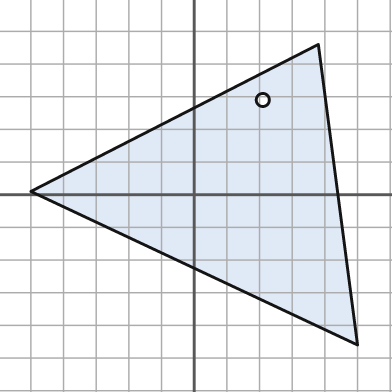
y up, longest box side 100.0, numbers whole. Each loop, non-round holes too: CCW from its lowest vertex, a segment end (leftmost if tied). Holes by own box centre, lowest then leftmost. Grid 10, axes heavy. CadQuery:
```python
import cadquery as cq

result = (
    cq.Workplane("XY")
    .moveTo(50.0, -46.0)
    .lineTo(38.0, 46.0)
    .lineTo(-50.0, 1.0)
    .close()
    .moveTo(21.0, 29.0)
    .circle(2.0)
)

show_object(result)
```